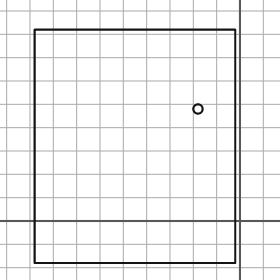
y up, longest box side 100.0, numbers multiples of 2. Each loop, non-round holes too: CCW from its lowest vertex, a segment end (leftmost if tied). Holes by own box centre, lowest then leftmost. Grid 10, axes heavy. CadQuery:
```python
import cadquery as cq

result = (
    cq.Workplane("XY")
    .moveTo(-88.0, -18.0)
    .lineTo(-2.0, -18.0)
    .lineTo(-2.0, 82.0)
    .lineTo(-88.0, 82.0)
    .close()
    .moveTo(-18.0, 48.0)
    .circle(2.0)
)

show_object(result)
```